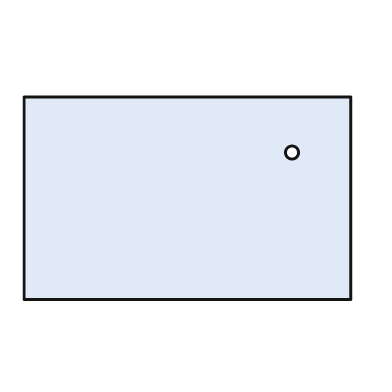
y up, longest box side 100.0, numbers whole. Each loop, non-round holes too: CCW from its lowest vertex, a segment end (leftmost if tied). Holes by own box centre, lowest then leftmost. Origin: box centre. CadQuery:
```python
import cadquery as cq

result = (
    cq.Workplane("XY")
    .moveTo(-50.0, -31.0)
    .lineTo(50.0, -31.0)
    .lineTo(50.0, 31.0)
    .lineTo(-50.0, 31.0)
    .close()
    .moveTo(32.0, 14.0)
    .circle(2.0)
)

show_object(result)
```